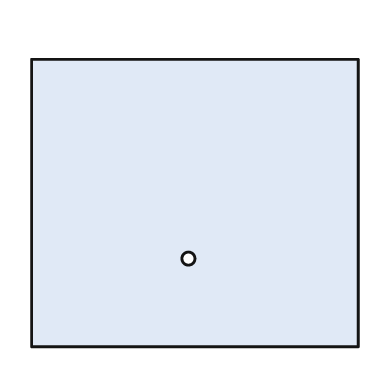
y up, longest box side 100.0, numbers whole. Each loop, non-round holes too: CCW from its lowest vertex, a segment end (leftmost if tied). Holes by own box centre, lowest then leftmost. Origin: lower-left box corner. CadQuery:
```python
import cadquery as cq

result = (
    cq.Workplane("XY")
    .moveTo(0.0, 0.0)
    .lineTo(100.0, 0.0)
    .lineTo(100.0, 88.0)
    .lineTo(0.0, 88.0)
    .close()
    .moveTo(48.0, 27.0)
    .circle(2.0)
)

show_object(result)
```